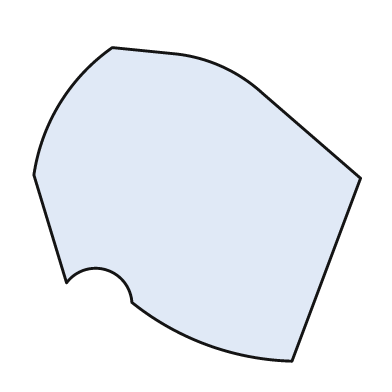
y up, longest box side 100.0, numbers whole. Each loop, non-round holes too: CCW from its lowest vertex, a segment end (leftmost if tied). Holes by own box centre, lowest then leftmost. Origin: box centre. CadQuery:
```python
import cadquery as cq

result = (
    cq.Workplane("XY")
    .moveTo(29.0, -48.0)
    .lineTo(50.0, 8.0)
    .lineTo(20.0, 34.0)
    .threePointArc((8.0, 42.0), (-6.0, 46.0))
    .lineTo(-26.0, 48.0)
    .threePointArc((-42.0, 31.0), (-50.0, 9.0))
    .lineTo(-40.0, -24.0)
    .threePointArc((-28.0, -20.0), (-20.0, -30.0))
    .threePointArc((3.0, -43.0), (29.0, -48.0))
    .close()
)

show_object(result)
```